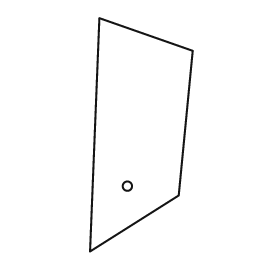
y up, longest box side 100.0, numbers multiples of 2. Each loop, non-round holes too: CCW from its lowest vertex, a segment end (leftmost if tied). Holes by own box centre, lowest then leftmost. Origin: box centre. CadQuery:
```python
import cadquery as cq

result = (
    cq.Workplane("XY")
    .moveTo(-22.0, -50.0)
    .lineTo(16.0, -26.0)
    .lineTo(22.0, 36.0)
    .lineTo(-18.0, 50.0)
    .close()
    .moveTo(-6.0, -22.0)
    .circle(2.0)
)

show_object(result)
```